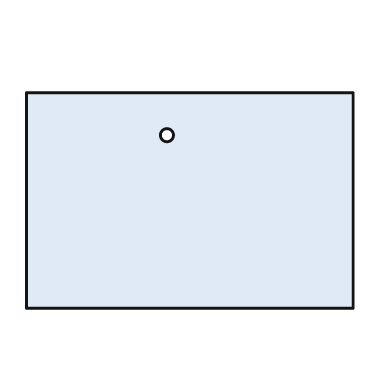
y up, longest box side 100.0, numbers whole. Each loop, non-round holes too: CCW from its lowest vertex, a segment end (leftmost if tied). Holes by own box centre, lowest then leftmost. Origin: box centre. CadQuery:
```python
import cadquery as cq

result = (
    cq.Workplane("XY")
    .moveTo(-50.0, -33.0)
    .lineTo(50.0, -33.0)
    .lineTo(50.0, 33.0)
    .lineTo(-50.0, 33.0)
    .close()
    .moveTo(-7.0, 20.0)
    .circle(2.0)
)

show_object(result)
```